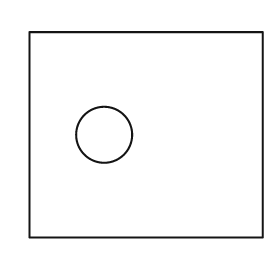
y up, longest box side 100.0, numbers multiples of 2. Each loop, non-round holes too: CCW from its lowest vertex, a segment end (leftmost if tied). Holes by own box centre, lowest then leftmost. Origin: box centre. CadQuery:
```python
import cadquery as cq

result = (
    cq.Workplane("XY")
    .moveTo(-50.0, -44.0)
    .lineTo(50.0, -44.0)
    .lineTo(50.0, 44.0)
    .lineTo(-50.0, 44.0)
    .close()
    .moveTo(-18.0, 0.0)
    .circle(12.0)
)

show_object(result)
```